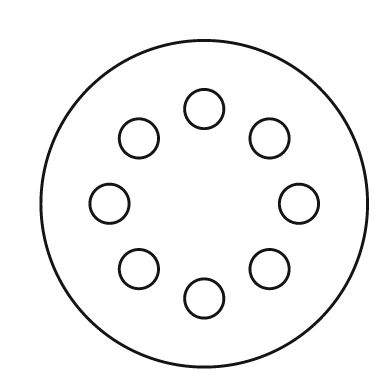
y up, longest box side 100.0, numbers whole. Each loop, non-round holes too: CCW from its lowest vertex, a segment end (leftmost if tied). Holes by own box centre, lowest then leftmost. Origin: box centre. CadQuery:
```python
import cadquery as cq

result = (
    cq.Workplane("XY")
    .moveTo(0.0, 0.0)
    .circle(50.0)
    .moveTo(0.0, -29.0)
    .circle(6.0)
    .moveTo(-20.0, -20.0)
    .circle(6.0)
    .moveTo(20.0, -20.0)
    .circle(6.0)
    .moveTo(-29.0, 0.0)
    .circle(6.0)
    .moveTo(29.0, 0.0)
    .circle(6.0)
    .moveTo(-20.0, 20.0)
    .circle(6.0)
    .moveTo(20.0, 20.0)
    .circle(6.0)
    .moveTo(0.0, 29.0)
    .circle(6.0)
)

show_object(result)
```